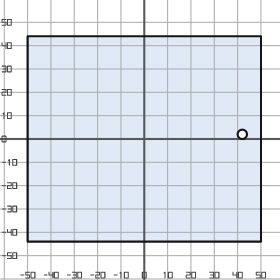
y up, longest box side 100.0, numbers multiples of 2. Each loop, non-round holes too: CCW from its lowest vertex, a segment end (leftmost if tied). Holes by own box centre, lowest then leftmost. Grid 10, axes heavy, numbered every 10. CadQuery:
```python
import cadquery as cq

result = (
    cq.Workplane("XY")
    .moveTo(-50.0, -44.0)
    .lineTo(50.0, -44.0)
    .lineTo(50.0, 44.0)
    .lineTo(-50.0, 44.0)
    .close()
    .moveTo(42.0, 2.0)
    .circle(2.0)
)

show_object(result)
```